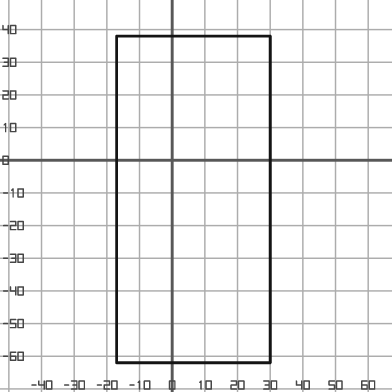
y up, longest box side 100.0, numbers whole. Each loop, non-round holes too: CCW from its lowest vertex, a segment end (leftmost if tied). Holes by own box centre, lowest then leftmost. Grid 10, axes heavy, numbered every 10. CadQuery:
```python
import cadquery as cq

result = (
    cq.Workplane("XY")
    .moveTo(-17.0, -62.0)
    .lineTo(30.0, -62.0)
    .lineTo(30.0, 38.0)
    .lineTo(-17.0, 38.0)
    .close()
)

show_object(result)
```